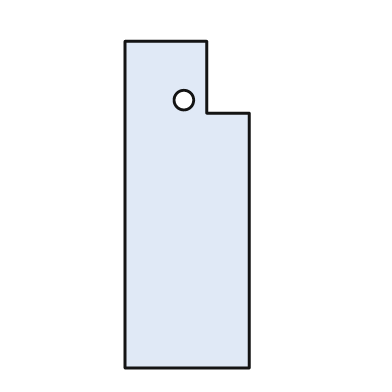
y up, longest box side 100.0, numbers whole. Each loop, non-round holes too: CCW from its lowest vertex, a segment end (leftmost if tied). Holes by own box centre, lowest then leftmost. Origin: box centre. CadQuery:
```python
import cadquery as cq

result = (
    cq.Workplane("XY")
    .moveTo(-19.0, -50.0)
    .lineTo(19.0, -50.0)
    .lineTo(19.0, 28.0)
    .lineTo(6.0, 28.0)
    .lineTo(6.0, 50.0)
    .lineTo(-19.0, 50.0)
    .close()
    .moveTo(-1.0, 32.0)
    .circle(3.0)
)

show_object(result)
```